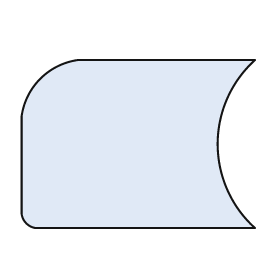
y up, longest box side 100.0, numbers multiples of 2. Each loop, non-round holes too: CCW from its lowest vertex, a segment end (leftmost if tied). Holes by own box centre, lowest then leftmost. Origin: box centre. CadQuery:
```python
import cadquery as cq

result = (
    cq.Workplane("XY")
    .moveTo(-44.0, -36.0)
    .lineTo(50.0, -36.0)
    .threePointArc((34.0, 0.0), (50.0, 36.0))
    .lineTo(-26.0, 36.0)
    .threePointArc((-42.0, 28.0), (-50.0, 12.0))
    .lineTo(-50.0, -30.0)
    .threePointArc((-48.0, -34.0), (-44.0, -36.0))
    .close()
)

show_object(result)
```